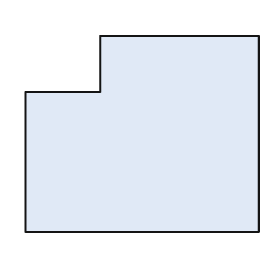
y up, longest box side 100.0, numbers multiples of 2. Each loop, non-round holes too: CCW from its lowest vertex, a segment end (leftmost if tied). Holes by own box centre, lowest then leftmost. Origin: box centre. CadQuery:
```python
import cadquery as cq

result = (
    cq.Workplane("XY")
    .moveTo(-50.0, -42.0)
    .lineTo(50.0, -42.0)
    .lineTo(50.0, 42.0)
    .lineTo(-18.0, 42.0)
    .lineTo(-18.0, 18.0)
    .lineTo(-50.0, 18.0)
    .close()
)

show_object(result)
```